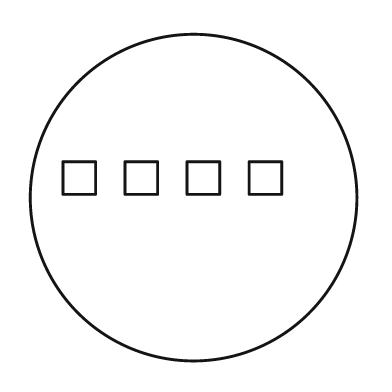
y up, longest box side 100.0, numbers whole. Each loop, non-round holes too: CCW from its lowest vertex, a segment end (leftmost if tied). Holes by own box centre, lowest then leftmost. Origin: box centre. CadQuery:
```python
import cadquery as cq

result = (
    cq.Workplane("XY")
    .moveTo(0.0, 0.0)
    .circle(50.0)
    .moveTo(-40.0, 1.0)
    .lineTo(-30.0, 1.0)
    .lineTo(-30.0, 11.0)
    .lineTo(-40.0, 11.0)
    .close()
    .moveTo(-21.0, 1.0)
    .lineTo(-11.0, 1.0)
    .lineTo(-11.0, 11.0)
    .lineTo(-21.0, 11.0)
    .close()
    .moveTo(-2.0, 1.0)
    .lineTo(8.0, 1.0)
    .lineTo(8.0, 11.0)
    .lineTo(-2.0, 11.0)
    .close()
    .moveTo(17.0, 1.0)
    .lineTo(27.0, 1.0)
    .lineTo(27.0, 11.0)
    .lineTo(17.0, 11.0)
    .close()
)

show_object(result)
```